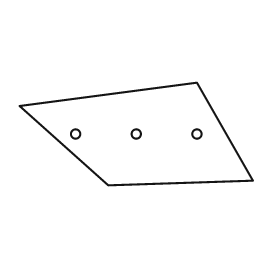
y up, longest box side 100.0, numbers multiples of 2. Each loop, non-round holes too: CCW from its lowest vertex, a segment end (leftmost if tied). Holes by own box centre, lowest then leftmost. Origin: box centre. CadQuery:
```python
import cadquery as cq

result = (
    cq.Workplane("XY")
    .moveTo(-12.0, -22.0)
    .lineTo(50.0, -20.0)
    .lineTo(26.0, 22.0)
    .lineTo(-50.0, 12.0)
    .close()
    .moveTo(-26.0, 0.0)
    .circle(2.0)
    .moveTo(0.0, 0.0)
    .circle(2.0)
    .moveTo(26.0, 0.0)
    .circle(2.0)
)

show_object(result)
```